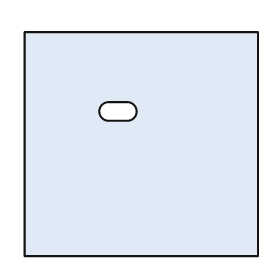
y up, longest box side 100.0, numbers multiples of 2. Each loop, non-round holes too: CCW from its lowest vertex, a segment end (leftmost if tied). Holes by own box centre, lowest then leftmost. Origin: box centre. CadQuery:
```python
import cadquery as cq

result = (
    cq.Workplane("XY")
    .moveTo(-50.0, -48.0)
    .lineTo(50.0, -48.0)
    .lineTo(50.0, 48.0)
    .lineTo(-50.0, 48.0)
    .close()
    .moveTo(-14.0, 10.0)
    .lineTo(-6.0, 10.0)
    .threePointArc((-2.0, 14.0), (-6.0, 18.0))
    .lineTo(-14.0, 18.0)
    .threePointArc((-18.0, 14.0), (-14.0, 10.0))
    .close()
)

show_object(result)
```